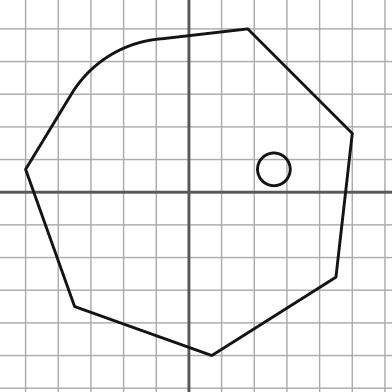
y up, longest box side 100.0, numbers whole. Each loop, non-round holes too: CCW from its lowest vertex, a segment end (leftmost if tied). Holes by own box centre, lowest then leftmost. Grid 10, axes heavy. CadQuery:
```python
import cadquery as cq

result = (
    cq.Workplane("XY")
    .moveTo(7.0, -50.0)
    .lineTo(45.0, -26.0)
    .lineTo(50.0, 18.0)
    .lineTo(18.0, 50.0)
    .lineTo(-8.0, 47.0)
    .threePointArc((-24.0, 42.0), (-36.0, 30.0))
    .lineTo(-50.0, 7.0)
    .lineTo(-35.0, -35.0)
    .close()
    .moveTo(26.0, 7.0)
    .circle(5.0)
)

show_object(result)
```